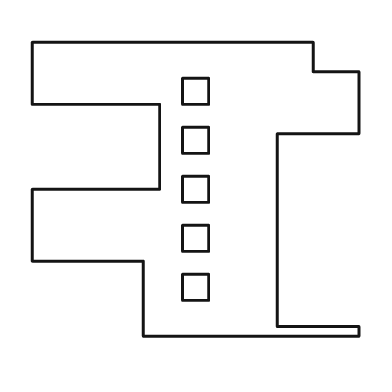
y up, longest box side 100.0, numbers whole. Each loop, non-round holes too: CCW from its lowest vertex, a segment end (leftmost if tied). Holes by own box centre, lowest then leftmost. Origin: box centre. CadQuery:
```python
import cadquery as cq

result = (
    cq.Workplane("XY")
    .moveTo(-16.0, -45.0)
    .lineTo(50.0, -45.0)
    .lineTo(50.0, -42.0)
    .lineTo(25.0, -42.0)
    .lineTo(25.0, 17.0)
    .lineTo(50.0, 17.0)
    .lineTo(50.0, 36.0)
    .lineTo(36.0, 36.0)
    .lineTo(36.0, 45.0)
    .lineTo(-50.0, 45.0)
    .lineTo(-50.0, 26.0)
    .lineTo(-11.0, 26.0)
    .lineTo(-11.0, 0.0)
    .lineTo(-50.0, 0.0)
    .lineTo(-50.0, -22.0)
    .lineTo(-16.0, -22.0)
    .close()
    .moveTo(-4.0, -34.0)
    .lineTo(4.0, -34.0)
    .lineTo(4.0, -26.0)
    .lineTo(-4.0, -26.0)
    .close()
    .moveTo(-4.0, -19.0)
    .lineTo(4.0, -19.0)
    .lineTo(4.0, -11.0)
    .lineTo(-4.0, -11.0)
    .close()
    .moveTo(-4.0, -4.0)
    .lineTo(4.0, -4.0)
    .lineTo(4.0, 4.0)
    .lineTo(-4.0, 4.0)
    .close()
    .moveTo(-4.0, 11.0)
    .lineTo(4.0, 11.0)
    .lineTo(4.0, 19.0)
    .lineTo(-4.0, 19.0)
    .close()
    .moveTo(-4.0, 26.0)
    .lineTo(4.0, 26.0)
    .lineTo(4.0, 34.0)
    .lineTo(-4.0, 34.0)
    .close()
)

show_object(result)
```